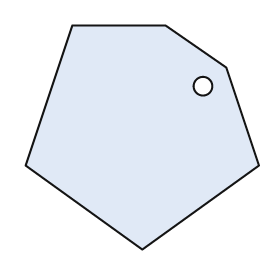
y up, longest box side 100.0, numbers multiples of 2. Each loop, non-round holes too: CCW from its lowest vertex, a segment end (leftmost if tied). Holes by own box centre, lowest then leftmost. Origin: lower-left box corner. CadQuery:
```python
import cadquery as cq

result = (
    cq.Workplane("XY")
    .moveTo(50.0, 0.0)
    .lineTo(100.0, 36.0)
    .lineTo(86.0, 78.0)
    .lineTo(60.0, 96.0)
    .lineTo(20.0, 96.0)
    .lineTo(0.0, 36.0)
    .close()
    .moveTo(76.0, 70.0)
    .circle(4.0)
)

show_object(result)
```